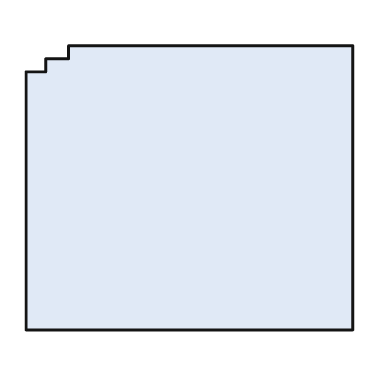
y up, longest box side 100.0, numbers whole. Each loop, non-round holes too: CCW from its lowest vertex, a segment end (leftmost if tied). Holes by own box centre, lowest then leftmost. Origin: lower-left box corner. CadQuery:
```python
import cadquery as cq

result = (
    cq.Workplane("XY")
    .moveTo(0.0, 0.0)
    .lineTo(100.0, 0.0)
    .lineTo(100.0, 87.0)
    .lineTo(13.0, 87.0)
    .lineTo(13.0, 83.0)
    .lineTo(6.0, 83.0)
    .lineTo(6.0, 79.0)
    .lineTo(0.0, 79.0)
    .close()
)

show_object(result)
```